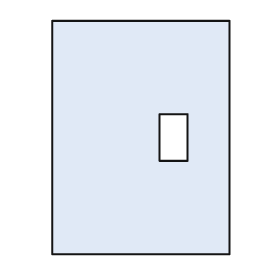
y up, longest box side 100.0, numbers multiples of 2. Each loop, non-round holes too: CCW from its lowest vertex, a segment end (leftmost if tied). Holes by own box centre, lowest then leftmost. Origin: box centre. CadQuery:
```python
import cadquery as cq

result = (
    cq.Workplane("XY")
    .moveTo(-38.0, -50.0)
    .lineTo(38.0, -50.0)
    .lineTo(38.0, 50.0)
    .lineTo(-38.0, 50.0)
    .close()
    .moveTo(8.0, -10.0)
    .lineTo(20.0, -10.0)
    .lineTo(20.0, 10.0)
    .lineTo(8.0, 10.0)
    .close()
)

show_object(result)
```